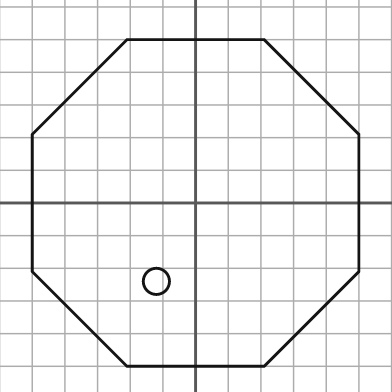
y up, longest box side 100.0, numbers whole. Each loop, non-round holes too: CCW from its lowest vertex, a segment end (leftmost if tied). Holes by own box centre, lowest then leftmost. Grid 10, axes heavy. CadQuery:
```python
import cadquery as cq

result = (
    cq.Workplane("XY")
    .moveTo(-21.0, -50.0)
    .lineTo(21.0, -50.0)
    .lineTo(50.0, -21.0)
    .lineTo(50.0, 21.0)
    .lineTo(21.0, 50.0)
    .lineTo(-21.0, 50.0)
    .lineTo(-50.0, 21.0)
    .lineTo(-50.0, -21.0)
    .close()
    .moveTo(-12.0, -24.0)
    .circle(4.0)
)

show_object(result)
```